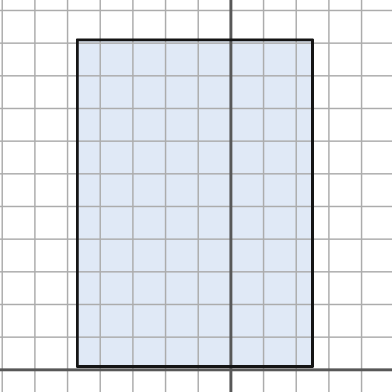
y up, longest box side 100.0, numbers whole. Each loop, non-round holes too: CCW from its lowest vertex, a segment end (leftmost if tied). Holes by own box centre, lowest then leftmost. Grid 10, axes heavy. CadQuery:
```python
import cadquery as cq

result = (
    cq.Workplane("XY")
    .moveTo(-47.0, 1.0)
    .lineTo(25.0, 1.0)
    .lineTo(25.0, 101.0)
    .lineTo(-47.0, 101.0)
    .close()
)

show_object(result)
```